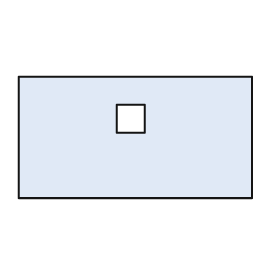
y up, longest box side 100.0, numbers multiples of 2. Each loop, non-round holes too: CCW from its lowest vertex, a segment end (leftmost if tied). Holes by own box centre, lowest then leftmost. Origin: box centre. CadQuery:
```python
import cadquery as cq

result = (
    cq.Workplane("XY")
    .moveTo(-50.0, -26.0)
    .lineTo(50.0, -26.0)
    .lineTo(50.0, 26.0)
    .lineTo(-50.0, 26.0)
    .close()
    .moveTo(-8.0, 2.0)
    .lineTo(4.0, 2.0)
    .lineTo(4.0, 14.0)
    .lineTo(-8.0, 14.0)
    .close()
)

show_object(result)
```